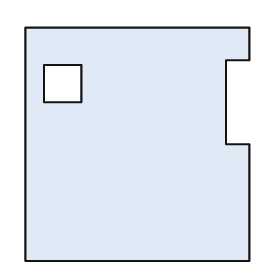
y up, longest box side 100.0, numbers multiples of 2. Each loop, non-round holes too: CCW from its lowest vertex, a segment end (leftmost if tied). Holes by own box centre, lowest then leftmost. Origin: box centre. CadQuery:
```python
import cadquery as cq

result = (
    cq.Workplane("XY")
    .moveTo(-48.0, -50.0)
    .lineTo(48.0, -50.0)
    .lineTo(48.0, 0.0)
    .lineTo(38.0, 0.0)
    .lineTo(38.0, 36.0)
    .lineTo(48.0, 36.0)
    .lineTo(48.0, 50.0)
    .lineTo(-48.0, 50.0)
    .close()
    .moveTo(-40.0, 18.0)
    .lineTo(-24.0, 18.0)
    .lineTo(-24.0, 34.0)
    .lineTo(-40.0, 34.0)
    .close()
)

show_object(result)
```